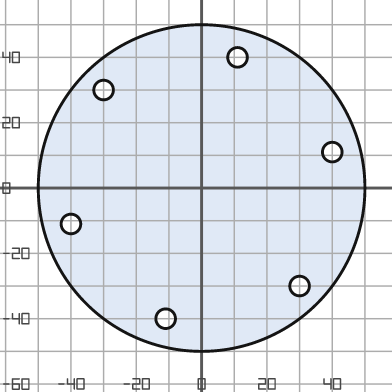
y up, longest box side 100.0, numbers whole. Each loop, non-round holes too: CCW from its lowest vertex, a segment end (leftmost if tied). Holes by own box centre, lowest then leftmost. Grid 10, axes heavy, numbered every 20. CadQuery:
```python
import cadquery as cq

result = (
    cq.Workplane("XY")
    .moveTo(0.0, 0.0)
    .circle(50.0)
    .moveTo(-11.0, -40.0)
    .circle(3.0)
    .moveTo(30.0, -30.0)
    .circle(3.0)
    .moveTo(-40.0, -11.0)
    .circle(3.0)
    .moveTo(40.0, 11.0)
    .circle(3.0)
    .moveTo(-30.0, 30.0)
    .circle(3.0)
    .moveTo(11.0, 40.0)
    .circle(3.0)
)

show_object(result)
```